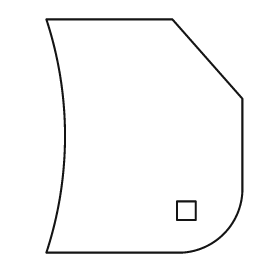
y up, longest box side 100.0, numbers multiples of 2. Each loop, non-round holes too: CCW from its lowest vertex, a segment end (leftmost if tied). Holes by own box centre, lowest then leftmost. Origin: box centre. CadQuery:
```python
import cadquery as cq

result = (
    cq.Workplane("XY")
    .moveTo(-42.0, -50.0)
    .lineTo(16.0, -50.0)
    .threePointArc((34.0, -42.0), (42.0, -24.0))
    .lineTo(42.0, 16.0)
    .lineTo(12.0, 50.0)
    .lineTo(-42.0, 50.0)
    .threePointArc((-34.0, 0.0), (-42.0, -50.0))
    .close()
    .moveTo(14.0, -36.0)
    .lineTo(22.0, -36.0)
    .lineTo(22.0, -28.0)
    .lineTo(14.0, -28.0)
    .close()
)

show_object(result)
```